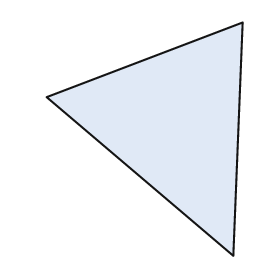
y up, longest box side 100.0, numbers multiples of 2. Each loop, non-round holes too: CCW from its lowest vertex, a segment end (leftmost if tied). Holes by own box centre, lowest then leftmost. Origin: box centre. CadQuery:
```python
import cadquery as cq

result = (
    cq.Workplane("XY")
    .moveTo(38.0, -50.0)
    .lineTo(42.0, 50.0)
    .lineTo(-42.0, 18.0)
    .close()
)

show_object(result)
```